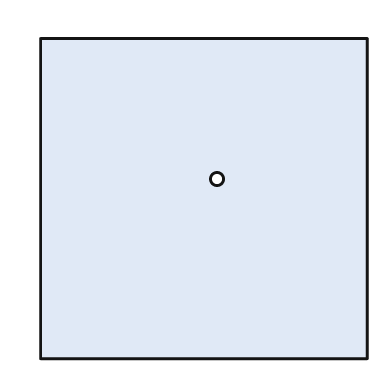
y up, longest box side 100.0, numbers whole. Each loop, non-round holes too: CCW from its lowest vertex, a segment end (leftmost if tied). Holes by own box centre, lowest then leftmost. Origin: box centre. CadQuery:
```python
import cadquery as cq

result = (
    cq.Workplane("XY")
    .moveTo(-50.0, -49.0)
    .lineTo(50.0, -49.0)
    .lineTo(50.0, 49.0)
    .lineTo(-50.0, 49.0)
    .close()
    .moveTo(4.0, 6.0)
    .circle(2.0)
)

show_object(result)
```